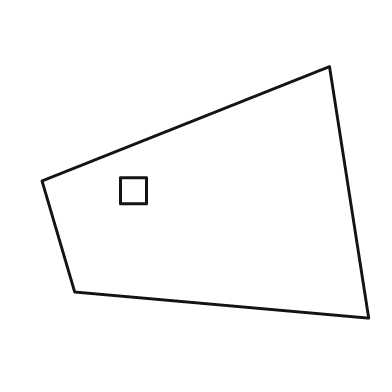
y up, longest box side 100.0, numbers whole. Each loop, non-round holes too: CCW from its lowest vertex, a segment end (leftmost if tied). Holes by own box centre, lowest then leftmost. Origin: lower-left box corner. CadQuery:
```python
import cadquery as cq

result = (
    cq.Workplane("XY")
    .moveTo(100.0, 0.0)
    .lineTo(88.0, 77.0)
    .lineTo(0.0, 42.0)
    .lineTo(10.0, 8.0)
    .close()
    .moveTo(24.0, 35.0)
    .lineTo(32.0, 35.0)
    .lineTo(32.0, 43.0)
    .lineTo(24.0, 43.0)
    .close()
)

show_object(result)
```